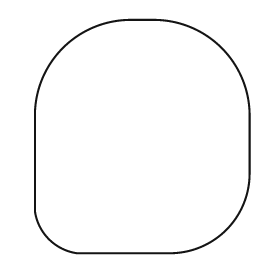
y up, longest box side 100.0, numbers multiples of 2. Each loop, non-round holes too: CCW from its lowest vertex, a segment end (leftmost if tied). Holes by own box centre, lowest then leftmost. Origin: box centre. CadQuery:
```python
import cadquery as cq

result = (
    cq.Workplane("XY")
    .moveTo(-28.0, -50.0)
    .lineTo(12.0, -50.0)
    .threePointArc((36.0, -40.0), (46.0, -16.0))
    .lineTo(46.0, 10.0)
    .threePointArc((34.0, 38.0), (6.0, 50.0))
    .lineTo(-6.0, 50.0)
    .threePointArc((-34.0, 38.0), (-46.0, 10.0))
    .lineTo(-46.0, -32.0)
    .threePointArc((-40.0, -44.0), (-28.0, -50.0))
    .close()
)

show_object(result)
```